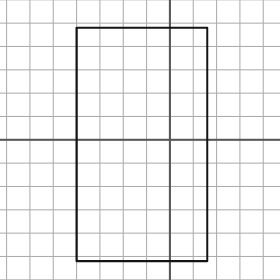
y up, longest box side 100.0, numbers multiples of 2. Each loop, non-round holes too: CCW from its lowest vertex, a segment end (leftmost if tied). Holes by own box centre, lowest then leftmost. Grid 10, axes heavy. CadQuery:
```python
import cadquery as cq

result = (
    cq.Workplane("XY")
    .moveTo(-40.0, -52.0)
    .lineTo(16.0, -52.0)
    .lineTo(16.0, 48.0)
    .lineTo(-40.0, 48.0)
    .close()
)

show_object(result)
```